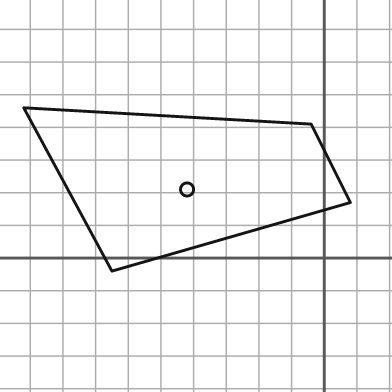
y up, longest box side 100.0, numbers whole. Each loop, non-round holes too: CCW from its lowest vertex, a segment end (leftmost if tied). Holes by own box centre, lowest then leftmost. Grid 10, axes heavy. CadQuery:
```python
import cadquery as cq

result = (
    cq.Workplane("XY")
    .moveTo(-65.0, -4.0)
    .lineTo(8.0, 17.0)
    .lineTo(-4.0, 41.0)
    .lineTo(-92.0, 46.0)
    .close()
    .moveTo(-42.0, 21.0)
    .circle(2.0)
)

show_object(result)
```